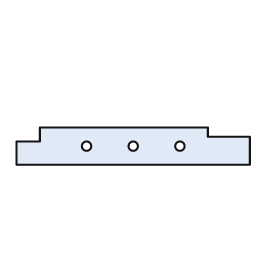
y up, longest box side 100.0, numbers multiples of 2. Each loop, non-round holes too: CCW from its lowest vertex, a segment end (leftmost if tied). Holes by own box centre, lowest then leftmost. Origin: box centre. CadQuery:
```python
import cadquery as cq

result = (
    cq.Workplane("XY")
    .moveTo(-50.0, -8.0)
    .lineTo(50.0, -8.0)
    .lineTo(50.0, 4.0)
    .lineTo(32.0, 4.0)
    .lineTo(32.0, 8.0)
    .lineTo(-40.0, 8.0)
    .lineTo(-40.0, 2.0)
    .lineTo(-50.0, 2.0)
    .close()
    .moveTo(-20.0, 0.0)
    .circle(2.0)
    .moveTo(0.0, 0.0)
    .circle(2.0)
    .moveTo(20.0, 0.0)
    .circle(2.0)
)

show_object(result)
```